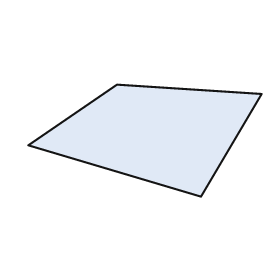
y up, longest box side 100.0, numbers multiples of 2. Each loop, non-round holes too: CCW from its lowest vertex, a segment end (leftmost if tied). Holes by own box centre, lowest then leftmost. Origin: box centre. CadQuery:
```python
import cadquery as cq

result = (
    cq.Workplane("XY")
    .moveTo(24.0, -24.0)
    .lineTo(50.0, 20.0)
    .lineTo(-12.0, 24.0)
    .lineTo(-50.0, -2.0)
    .close()
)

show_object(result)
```